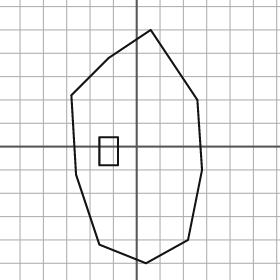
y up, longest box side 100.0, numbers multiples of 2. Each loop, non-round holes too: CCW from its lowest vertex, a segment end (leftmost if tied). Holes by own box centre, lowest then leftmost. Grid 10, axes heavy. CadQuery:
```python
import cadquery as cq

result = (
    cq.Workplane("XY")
    .moveTo(4.0, -50.0)
    .lineTo(22.0, -40.0)
    .lineTo(28.0, -10.0)
    .lineTo(26.0, 20.0)
    .lineTo(6.0, 50.0)
    .lineTo(-12.0, 38.0)
    .lineTo(-28.0, 22.0)
    .lineTo(-26.0, -12.0)
    .lineTo(-16.0, -42.0)
    .close()
    .moveTo(-16.0, -8.0)
    .lineTo(-8.0, -8.0)
    .lineTo(-8.0, 4.0)
    .lineTo(-16.0, 4.0)
    .close()
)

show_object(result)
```